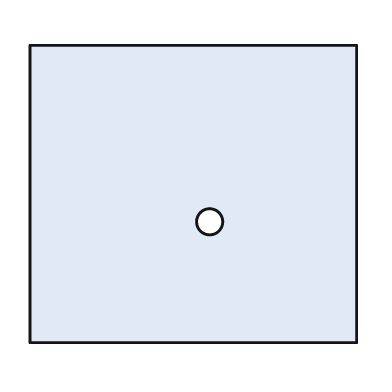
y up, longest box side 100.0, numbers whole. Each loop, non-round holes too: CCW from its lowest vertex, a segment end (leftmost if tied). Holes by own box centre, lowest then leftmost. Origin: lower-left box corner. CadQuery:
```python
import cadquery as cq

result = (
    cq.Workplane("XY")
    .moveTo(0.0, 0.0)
    .lineTo(100.0, 0.0)
    .lineTo(100.0, 91.0)
    .lineTo(0.0, 91.0)
    .close()
    .moveTo(55.0, 37.0)
    .circle(4.0)
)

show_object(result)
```